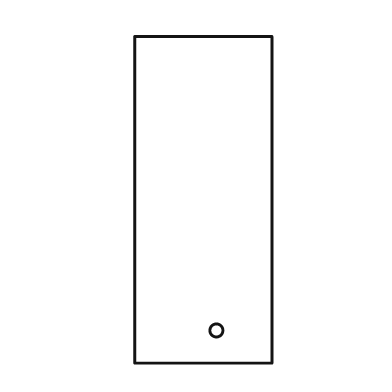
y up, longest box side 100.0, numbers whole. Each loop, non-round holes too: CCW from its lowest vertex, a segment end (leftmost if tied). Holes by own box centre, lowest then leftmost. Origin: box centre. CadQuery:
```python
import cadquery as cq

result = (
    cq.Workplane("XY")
    .moveTo(-21.0, -50.0)
    .lineTo(21.0, -50.0)
    .lineTo(21.0, 50.0)
    .lineTo(-21.0, 50.0)
    .close()
    .moveTo(4.0, -40.0)
    .circle(2.0)
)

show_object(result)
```